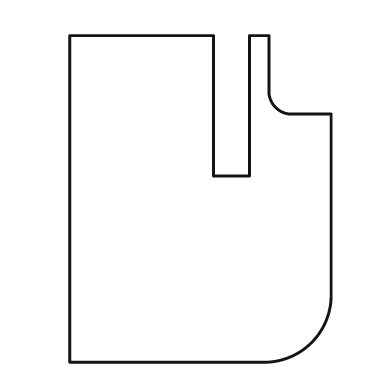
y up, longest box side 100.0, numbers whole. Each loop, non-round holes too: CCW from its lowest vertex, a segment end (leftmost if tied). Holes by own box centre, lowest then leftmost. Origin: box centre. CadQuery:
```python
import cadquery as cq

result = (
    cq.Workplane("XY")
    .moveTo(-40.0, -50.0)
    .lineTo(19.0, -50.0)
    .threePointArc((34.0, -44.0), (40.0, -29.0))
    .lineTo(40.0, 26.0)
    .lineTo(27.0, 26.0)
    .threePointArc((23.0, 28.0), (21.0, 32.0))
    .lineTo(21.0, 50.0)
    .lineTo(15.0, 50.0)
    .lineTo(15.0, 7.0)
    .lineTo(4.0, 7.0)
    .lineTo(4.0, 50.0)
    .lineTo(-40.0, 50.0)
    .close()
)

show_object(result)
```